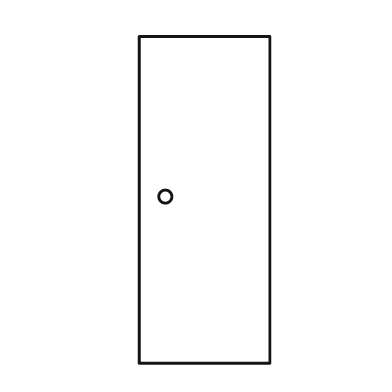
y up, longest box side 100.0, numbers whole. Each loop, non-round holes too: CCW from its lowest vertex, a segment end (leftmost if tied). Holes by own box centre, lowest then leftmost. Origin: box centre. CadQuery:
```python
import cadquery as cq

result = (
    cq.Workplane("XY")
    .moveTo(-20.0, -50.0)
    .lineTo(20.0, -50.0)
    .lineTo(20.0, 50.0)
    .lineTo(-20.0, 50.0)
    .close()
    .moveTo(-12.0, 1.0)
    .circle(2.0)
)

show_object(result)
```